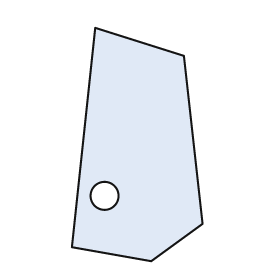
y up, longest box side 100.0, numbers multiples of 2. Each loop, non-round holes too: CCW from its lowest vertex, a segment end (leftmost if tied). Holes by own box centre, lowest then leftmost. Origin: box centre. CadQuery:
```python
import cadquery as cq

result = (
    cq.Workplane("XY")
    .moveTo(6.0, -50.0)
    .lineTo(28.0, -34.0)
    .lineTo(20.0, 38.0)
    .lineTo(-18.0, 50.0)
    .lineTo(-28.0, -44.0)
    .close()
    .moveTo(-14.0, -22.0)
    .circle(6.0)
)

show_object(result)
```